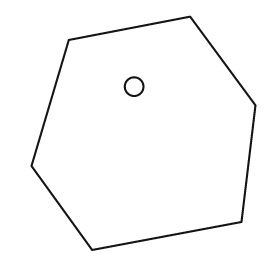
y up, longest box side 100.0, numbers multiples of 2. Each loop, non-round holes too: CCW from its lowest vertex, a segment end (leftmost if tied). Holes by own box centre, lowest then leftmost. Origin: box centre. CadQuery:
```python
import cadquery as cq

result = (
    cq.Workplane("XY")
    .moveTo(-22.0, -50.0)
    .lineTo(42.0, -38.0)
    .lineTo(48.0, 12.0)
    .lineTo(20.0, 50.0)
    .lineTo(-32.0, 40.0)
    .lineTo(-48.0, -14.0)
    .close()
    .moveTo(-4.0, 20.0)
    .circle(4.0)
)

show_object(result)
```